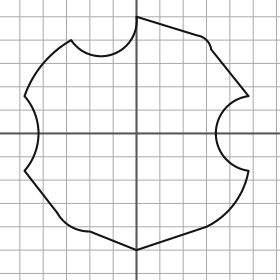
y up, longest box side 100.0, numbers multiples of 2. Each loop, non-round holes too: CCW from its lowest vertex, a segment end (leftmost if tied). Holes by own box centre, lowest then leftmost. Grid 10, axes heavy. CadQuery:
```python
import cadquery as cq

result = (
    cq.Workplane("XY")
    .moveTo(0.0, -50.0)
    .lineTo(30.0, -40.0)
    .threePointArc((42.0, -30.0), (48.0, -16.0))
    .threePointArc((34.0, 0.0), (48.0, 16.0))
    .lineTo(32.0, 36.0)
    .threePointArc((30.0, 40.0), (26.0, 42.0))
    .lineTo(0.0, 50.0)
    .threePointArc((-10.0, 34.0), (-28.0, 40.0))
    .threePointArc((-40.0, 30.0), (-48.0, 16.0))
    .threePointArc((-42.0, 0.0), (-48.0, -16.0))
    .lineTo(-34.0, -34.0)
    .threePointArc((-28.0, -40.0), (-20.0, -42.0))
    .close()
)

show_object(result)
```